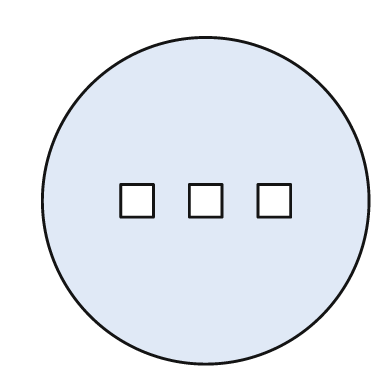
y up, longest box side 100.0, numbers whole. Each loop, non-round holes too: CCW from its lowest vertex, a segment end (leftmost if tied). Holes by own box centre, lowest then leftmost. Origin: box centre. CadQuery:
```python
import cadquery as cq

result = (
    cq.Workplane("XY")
    .moveTo(0.0, 0.0)
    .circle(50.0)
    .moveTo(-26.0, -5.0)
    .lineTo(-16.0, -5.0)
    .lineTo(-16.0, 5.0)
    .lineTo(-26.0, 5.0)
    .close()
    .moveTo(-5.0, -5.0)
    .lineTo(5.0, -5.0)
    .lineTo(5.0, 5.0)
    .lineTo(-5.0, 5.0)
    .close()
    .moveTo(16.0, -5.0)
    .lineTo(26.0, -5.0)
    .lineTo(26.0, 5.0)
    .lineTo(16.0, 5.0)
    .close()
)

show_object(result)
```